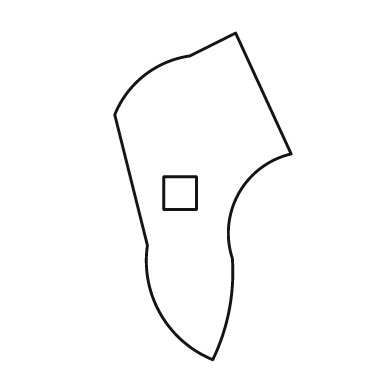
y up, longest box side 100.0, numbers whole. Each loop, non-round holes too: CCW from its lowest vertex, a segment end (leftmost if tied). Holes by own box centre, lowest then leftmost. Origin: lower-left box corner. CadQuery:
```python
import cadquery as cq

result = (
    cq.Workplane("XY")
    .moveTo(30.0, 0.0)
    .threePointArc((35.0, 15.0), (36.0, 31.0))
    .threePointArc((38.0, 51.0), (54.0, 63.0))
    .lineTo(37.0, 100.0)
    .lineTo(23.0, 93.0)
    .threePointArc((9.0, 87.0), (0.0, 75.0))
    .lineTo(10.0, 35.0)
    .threePointArc((14.0, 14.0), (30.0, 0.0))
    .close()
    .moveTo(15.0, 46.0)
    .lineTo(25.0, 46.0)
    .lineTo(25.0, 56.0)
    .lineTo(15.0, 56.0)
    .close()
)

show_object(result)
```